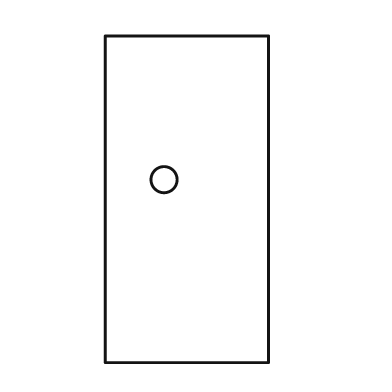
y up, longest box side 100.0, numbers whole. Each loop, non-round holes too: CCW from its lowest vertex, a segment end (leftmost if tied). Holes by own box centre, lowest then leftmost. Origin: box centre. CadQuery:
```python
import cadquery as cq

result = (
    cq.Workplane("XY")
    .moveTo(-25.0, -50.0)
    .lineTo(25.0, -50.0)
    .lineTo(25.0, 50.0)
    .lineTo(-25.0, 50.0)
    .close()
    .moveTo(-7.0, 6.0)
    .circle(4.0)
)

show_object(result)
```